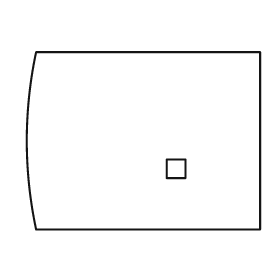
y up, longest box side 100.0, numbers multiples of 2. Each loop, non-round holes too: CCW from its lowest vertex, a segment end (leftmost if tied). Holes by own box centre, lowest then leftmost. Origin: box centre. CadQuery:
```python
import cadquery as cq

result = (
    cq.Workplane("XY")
    .moveTo(-46.0, -38.0)
    .lineTo(50.0, -38.0)
    .lineTo(50.0, 38.0)
    .lineTo(-46.0, 38.0)
    .threePointArc((-50.0, 0.0), (-46.0, -38.0))
    .close()
    .moveTo(10.0, -16.0)
    .lineTo(18.0, -16.0)
    .lineTo(18.0, -8.0)
    .lineTo(10.0, -8.0)
    .close()
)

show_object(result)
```